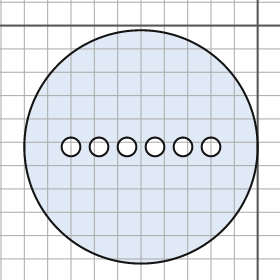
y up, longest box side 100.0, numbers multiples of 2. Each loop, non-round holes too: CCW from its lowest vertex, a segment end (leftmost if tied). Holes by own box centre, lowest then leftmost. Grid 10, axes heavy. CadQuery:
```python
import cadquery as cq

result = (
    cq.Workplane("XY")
    .moveTo(-50.0, -52.0)
    .circle(50.0)
    .moveTo(-80.0, -52.0)
    .circle(4.0)
    .moveTo(-68.0, -52.0)
    .circle(4.0)
    .moveTo(-56.0, -52.0)
    .circle(4.0)
    .moveTo(-44.0, -52.0)
    .circle(4.0)
    .moveTo(-32.0, -52.0)
    .circle(4.0)
    .moveTo(-20.0, -52.0)
    .circle(4.0)
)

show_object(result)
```